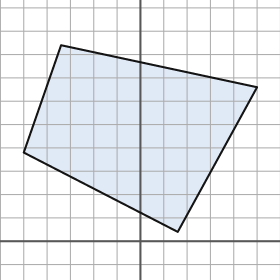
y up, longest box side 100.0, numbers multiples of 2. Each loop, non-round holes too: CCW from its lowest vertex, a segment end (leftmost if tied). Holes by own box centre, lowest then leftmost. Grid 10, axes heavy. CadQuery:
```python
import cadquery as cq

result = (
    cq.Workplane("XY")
    .moveTo(16.0, 4.0)
    .lineTo(50.0, 66.0)
    .lineTo(-34.0, 84.0)
    .lineTo(-50.0, 38.0)
    .close()
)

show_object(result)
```